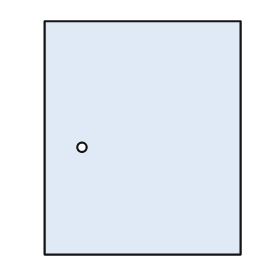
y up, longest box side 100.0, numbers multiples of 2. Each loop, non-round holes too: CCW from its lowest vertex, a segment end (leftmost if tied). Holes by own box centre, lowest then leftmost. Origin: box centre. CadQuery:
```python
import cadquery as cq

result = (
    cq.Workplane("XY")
    .moveTo(-42.0, -50.0)
    .lineTo(42.0, -50.0)
    .lineTo(42.0, 50.0)
    .lineTo(-42.0, 50.0)
    .close()
    .moveTo(-26.0, -4.0)
    .circle(2.0)
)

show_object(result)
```